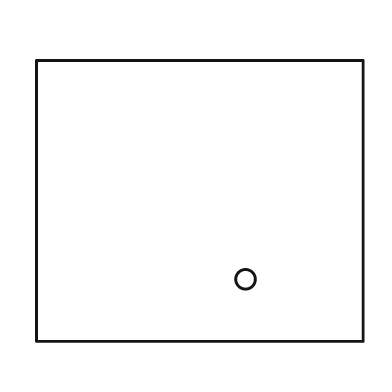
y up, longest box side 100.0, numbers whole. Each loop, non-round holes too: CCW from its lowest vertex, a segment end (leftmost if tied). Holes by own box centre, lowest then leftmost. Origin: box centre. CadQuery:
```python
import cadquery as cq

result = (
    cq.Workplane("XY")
    .moveTo(-50.0, -43.0)
    .lineTo(50.0, -43.0)
    .lineTo(50.0, 43.0)
    .lineTo(-50.0, 43.0)
    .close()
    .moveTo(14.0, -24.0)
    .circle(3.0)
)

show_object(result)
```